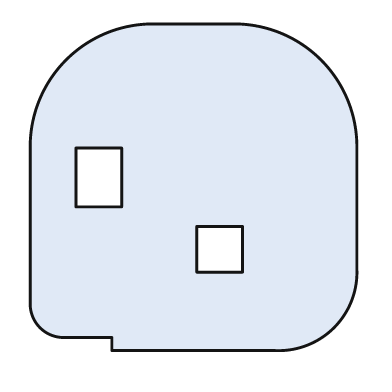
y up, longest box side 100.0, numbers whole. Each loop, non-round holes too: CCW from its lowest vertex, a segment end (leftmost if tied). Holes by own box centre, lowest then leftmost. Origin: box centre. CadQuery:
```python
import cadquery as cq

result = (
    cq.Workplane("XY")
    .moveTo(-25.0, -50.0)
    .lineTo(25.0, -50.0)
    .threePointArc((43.0, -43.0), (50.0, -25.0))
    .lineTo(50.0, 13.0)
    .threePointArc((39.0, 39.0), (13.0, 50.0))
    .lineTo(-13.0, 50.0)
    .threePointArc((-39.0, 39.0), (-50.0, 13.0))
    .lineTo(-50.0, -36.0)
    .threePointArc((-47.0, -43.0), (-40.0, -46.0))
    .lineTo(-25.0, -46.0)
    .close()
    .moveTo(1.0, -26.0)
    .lineTo(15.0, -26.0)
    .lineTo(15.0, -12.0)
    .lineTo(1.0, -12.0)
    .close()
    .moveTo(-36.0, -6.0)
    .lineTo(-22.0, -6.0)
    .lineTo(-22.0, 12.0)
    .lineTo(-36.0, 12.0)
    .close()
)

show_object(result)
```